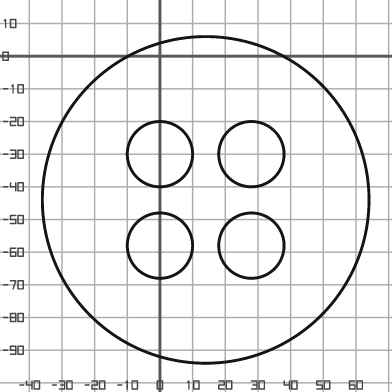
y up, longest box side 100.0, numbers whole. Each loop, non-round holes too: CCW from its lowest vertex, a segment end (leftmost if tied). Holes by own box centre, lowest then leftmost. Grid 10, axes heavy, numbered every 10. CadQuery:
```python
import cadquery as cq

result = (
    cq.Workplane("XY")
    .moveTo(14.0, -44.0)
    .circle(50.0)
    .moveTo(0.0, -58.0)
    .circle(10.0)
    .moveTo(28.0, -58.0)
    .circle(10.0)
    .moveTo(0.0, -30.0)
    .circle(10.0)
    .moveTo(28.0, -30.0)
    .circle(10.0)
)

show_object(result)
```